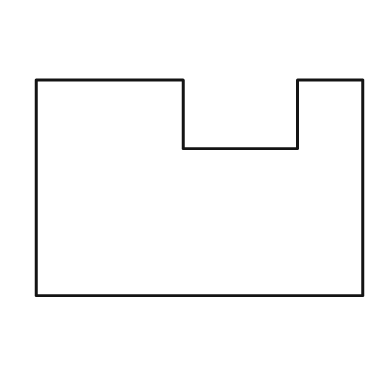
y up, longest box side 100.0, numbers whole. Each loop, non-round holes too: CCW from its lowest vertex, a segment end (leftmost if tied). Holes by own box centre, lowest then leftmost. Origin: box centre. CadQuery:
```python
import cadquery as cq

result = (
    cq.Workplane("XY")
    .moveTo(-50.0, -33.0)
    .lineTo(50.0, -33.0)
    .lineTo(50.0, 33.0)
    .lineTo(30.0, 33.0)
    .lineTo(30.0, 12.0)
    .lineTo(-5.0, 12.0)
    .lineTo(-5.0, 33.0)
    .lineTo(-50.0, 33.0)
    .close()
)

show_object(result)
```